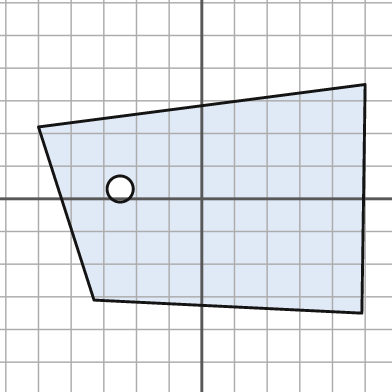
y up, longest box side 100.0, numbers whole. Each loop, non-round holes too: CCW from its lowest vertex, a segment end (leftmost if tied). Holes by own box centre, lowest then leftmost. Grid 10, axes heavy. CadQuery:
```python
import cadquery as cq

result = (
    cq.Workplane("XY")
    .moveTo(49.0, -35.0)
    .lineTo(50.0, 35.0)
    .lineTo(-50.0, 22.0)
    .lineTo(-33.0, -31.0)
    .close()
    .moveTo(-25.0, 3.0)
    .circle(4.0)
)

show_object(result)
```